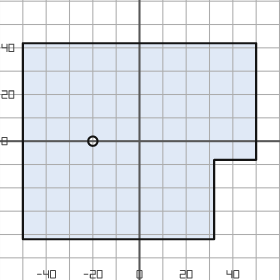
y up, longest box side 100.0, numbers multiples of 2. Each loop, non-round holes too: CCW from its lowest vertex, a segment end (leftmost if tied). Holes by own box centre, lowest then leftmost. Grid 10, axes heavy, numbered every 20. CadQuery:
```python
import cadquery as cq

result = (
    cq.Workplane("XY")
    .moveTo(-50.0, -42.0)
    .lineTo(32.0, -42.0)
    .lineTo(32.0, -8.0)
    .lineTo(50.0, -8.0)
    .lineTo(50.0, 42.0)
    .lineTo(-50.0, 42.0)
    .close()
    .moveTo(-20.0, 0.0)
    .circle(2.0)
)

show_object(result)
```